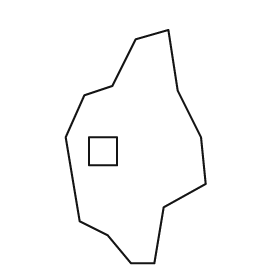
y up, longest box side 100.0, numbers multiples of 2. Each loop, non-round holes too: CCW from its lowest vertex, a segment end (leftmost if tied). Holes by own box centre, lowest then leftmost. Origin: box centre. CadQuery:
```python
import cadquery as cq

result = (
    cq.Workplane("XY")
    .moveTo(-2.0, -50.0)
    .lineTo(8.0, -50.0)
    .lineTo(12.0, -26.0)
    .lineTo(30.0, -16.0)
    .lineTo(28.0, 4.0)
    .lineTo(18.0, 24.0)
    .lineTo(14.0, 50.0)
    .lineTo(0.0, 46.0)
    .lineTo(-10.0, 26.0)
    .lineTo(-22.0, 22.0)
    .lineTo(-30.0, 4.0)
    .lineTo(-24.0, -32.0)
    .lineTo(-12.0, -38.0)
    .close()
    .moveTo(-20.0, -8.0)
    .lineTo(-8.0, -8.0)
    .lineTo(-8.0, 4.0)
    .lineTo(-20.0, 4.0)
    .close()
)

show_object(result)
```